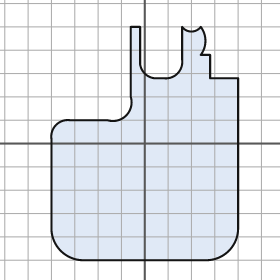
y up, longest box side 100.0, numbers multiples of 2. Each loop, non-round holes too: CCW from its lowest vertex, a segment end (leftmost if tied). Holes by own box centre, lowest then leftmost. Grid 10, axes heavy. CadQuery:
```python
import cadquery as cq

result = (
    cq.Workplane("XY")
    .moveTo(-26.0, -50.0)
    .lineTo(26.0, -50.0)
    .threePointArc((36.0, -46.0), (40.0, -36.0))
    .lineTo(40.0, 28.0)
    .lineTo(28.0, 28.0)
    .lineTo(28.0, 38.0)
    .lineTo(24.0, 38.0)
    .threePointArc((26.0, 44.0), (24.0, 50.0))
    .threePointArc((20.0, 48.0), (16.0, 50.0))
    .lineTo(16.0, 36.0)
    .threePointArc((14.0, 30.0), (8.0, 28.0))
    .lineTo(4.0, 28.0)
    .threePointArc((0.0, 30.0), (-2.0, 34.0))
    .lineTo(-2.0, 50.0)
    .lineTo(-6.0, 50.0)
    .lineTo(-6.0, 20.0)
    .threePointArc((-8.0, 12.0), (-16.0, 10.0))
    .lineTo(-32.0, 10.0)
    .threePointArc((-38.0, 8.0), (-40.0, 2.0))
    .lineTo(-40.0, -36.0)
    .threePointArc((-36.0, -46.0), (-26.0, -50.0))
    .close()
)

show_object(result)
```